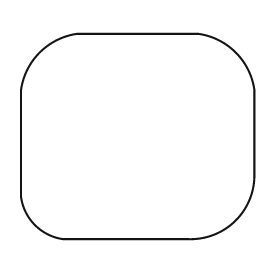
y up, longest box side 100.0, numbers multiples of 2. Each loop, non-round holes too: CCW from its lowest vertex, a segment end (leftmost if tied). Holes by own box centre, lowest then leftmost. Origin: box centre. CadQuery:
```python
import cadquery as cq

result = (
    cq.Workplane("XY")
    .moveTo(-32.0, -44.0)
    .lineTo(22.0, -44.0)
    .threePointArc((42.0, -36.0), (50.0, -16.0))
    .lineTo(50.0, 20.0)
    .threePointArc((42.0, 36.0), (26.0, 44.0))
    .lineTo(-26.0, 44.0)
    .threePointArc((-42.0, 36.0), (-50.0, 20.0))
    .lineTo(-50.0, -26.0)
    .threePointArc((-44.0, -38.0), (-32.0, -44.0))
    .close()
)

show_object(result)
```